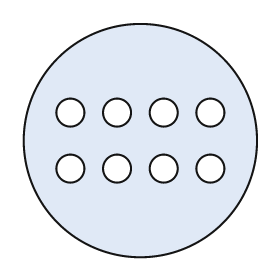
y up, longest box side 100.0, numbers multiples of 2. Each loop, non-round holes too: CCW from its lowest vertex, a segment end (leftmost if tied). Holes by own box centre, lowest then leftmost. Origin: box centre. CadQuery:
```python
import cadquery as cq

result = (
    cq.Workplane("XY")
    .moveTo(0.0, 0.0)
    .circle(50.0)
    .moveTo(-30.0, -12.0)
    .circle(6.0)
    .moveTo(-10.0, -12.0)
    .circle(6.0)
    .moveTo(10.0, -12.0)
    .circle(6.0)
    .moveTo(30.0, -12.0)
    .circle(6.0)
    .moveTo(-30.0, 12.0)
    .circle(6.0)
    .moveTo(-10.0, 12.0)
    .circle(6.0)
    .moveTo(10.0, 12.0)
    .circle(6.0)
    .moveTo(30.0, 12.0)
    .circle(6.0)
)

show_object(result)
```